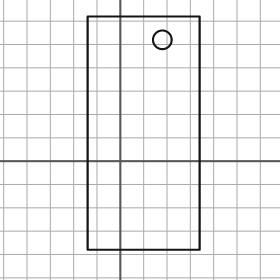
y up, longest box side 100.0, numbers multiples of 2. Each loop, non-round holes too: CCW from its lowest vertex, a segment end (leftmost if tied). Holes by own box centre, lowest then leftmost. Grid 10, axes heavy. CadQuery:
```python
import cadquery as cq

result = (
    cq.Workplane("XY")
    .moveTo(-14.0, -38.0)
    .lineTo(34.0, -38.0)
    .lineTo(34.0, 62.0)
    .lineTo(-14.0, 62.0)
    .close()
    .moveTo(18.0, 52.0)
    .circle(4.0)
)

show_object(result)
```